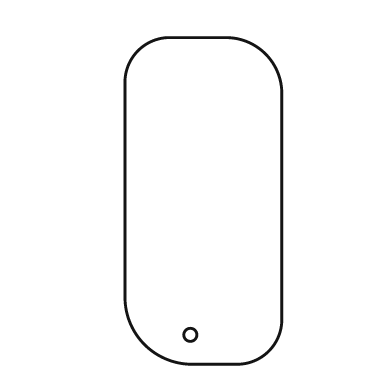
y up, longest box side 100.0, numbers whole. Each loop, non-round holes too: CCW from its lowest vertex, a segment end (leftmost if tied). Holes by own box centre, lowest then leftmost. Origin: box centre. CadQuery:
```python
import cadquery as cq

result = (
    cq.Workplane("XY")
    .moveTo(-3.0, -50.0)
    .lineTo(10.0, -50.0)
    .threePointArc((20.0, -46.0), (24.0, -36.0))
    .lineTo(24.0, 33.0)
    .threePointArc((19.0, 45.0), (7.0, 50.0))
    .lineTo(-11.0, 50.0)
    .threePointArc((-20.0, 46.0), (-24.0, 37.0))
    .lineTo(-24.0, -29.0)
    .threePointArc((-18.0, -44.0), (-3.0, -50.0))
    .close()
    .moveTo(-4.0, -41.0)
    .circle(2.0)
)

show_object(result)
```